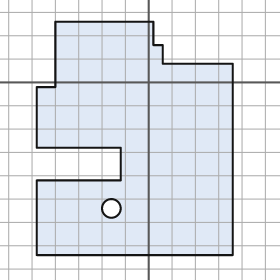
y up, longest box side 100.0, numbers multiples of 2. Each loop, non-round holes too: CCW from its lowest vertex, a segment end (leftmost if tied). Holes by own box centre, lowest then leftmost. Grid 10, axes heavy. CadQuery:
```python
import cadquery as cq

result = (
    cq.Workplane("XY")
    .moveTo(-48.0, -74.0)
    .lineTo(36.0, -74.0)
    .lineTo(36.0, 8.0)
    .lineTo(6.0, 8.0)
    .lineTo(6.0, 16.0)
    .lineTo(2.0, 16.0)
    .lineTo(2.0, 26.0)
    .lineTo(-40.0, 26.0)
    .lineTo(-40.0, -2.0)
    .lineTo(-48.0, -2.0)
    .lineTo(-48.0, -28.0)
    .lineTo(-12.0, -28.0)
    .lineTo(-12.0, -42.0)
    .lineTo(-48.0, -42.0)
    .close()
    .moveTo(-16.0, -54.0)
    .circle(4.0)
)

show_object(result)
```